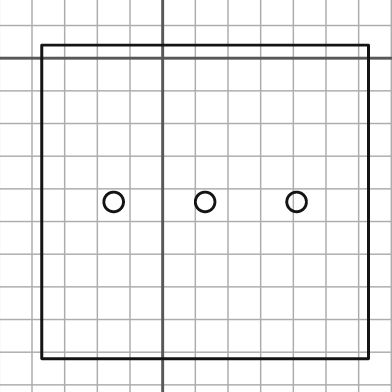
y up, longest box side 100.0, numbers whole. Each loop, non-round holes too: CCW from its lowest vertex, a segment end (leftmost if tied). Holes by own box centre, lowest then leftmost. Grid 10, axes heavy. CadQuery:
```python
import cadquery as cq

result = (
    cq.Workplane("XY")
    .moveTo(-37.0, -92.0)
    .lineTo(63.0, -92.0)
    .lineTo(63.0, 4.0)
    .lineTo(-37.0, 4.0)
    .close()
    .moveTo(-15.0, -44.0)
    .circle(3.0)
    .moveTo(13.0, -44.0)
    .circle(3.0)
    .moveTo(41.0, -44.0)
    .circle(3.0)
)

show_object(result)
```